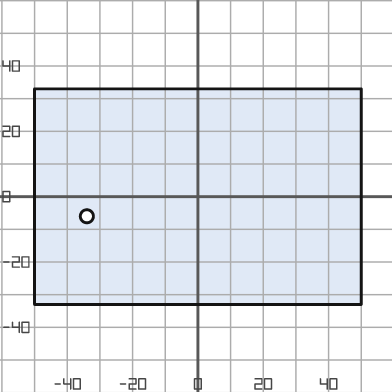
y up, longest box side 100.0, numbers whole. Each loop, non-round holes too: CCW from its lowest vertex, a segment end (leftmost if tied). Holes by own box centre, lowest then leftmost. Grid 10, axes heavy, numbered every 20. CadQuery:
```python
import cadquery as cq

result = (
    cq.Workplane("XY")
    .moveTo(-50.0, -33.0)
    .lineTo(50.0, -33.0)
    .lineTo(50.0, 33.0)
    .lineTo(-50.0, 33.0)
    .close()
    .moveTo(-34.0, -6.0)
    .circle(2.0)
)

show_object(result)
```